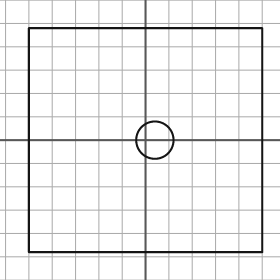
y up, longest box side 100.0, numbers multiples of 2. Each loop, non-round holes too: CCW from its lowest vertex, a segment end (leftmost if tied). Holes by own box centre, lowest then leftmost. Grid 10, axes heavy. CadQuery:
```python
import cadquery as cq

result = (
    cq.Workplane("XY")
    .moveTo(-50.0, -48.0)
    .lineTo(50.0, -48.0)
    .lineTo(50.0, 48.0)
    .lineTo(-50.0, 48.0)
    .close()
    .moveTo(4.0, 0.0)
    .circle(8.0)
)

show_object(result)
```